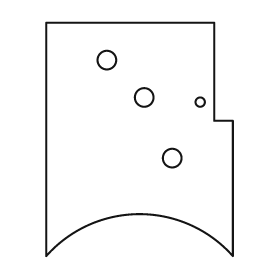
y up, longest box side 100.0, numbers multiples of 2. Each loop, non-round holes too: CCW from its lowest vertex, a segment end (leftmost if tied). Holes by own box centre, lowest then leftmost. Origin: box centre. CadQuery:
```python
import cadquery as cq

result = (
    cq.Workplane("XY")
    .moveTo(-40.0, -50.0)
    .threePointArc((0.0, -32.0), (40.0, -50.0))
    .lineTo(40.0, 8.0)
    .lineTo(32.0, 8.0)
    .lineTo(32.0, 50.0)
    .lineTo(-40.0, 50.0)
    .close()
    .moveTo(14.0, -8.0)
    .circle(4.0)
    .moveTo(26.0, 16.0)
    .circle(2.0)
    .moveTo(2.0, 18.0)
    .circle(4.0)
    .moveTo(-14.0, 34.0)
    .circle(4.0)
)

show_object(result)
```